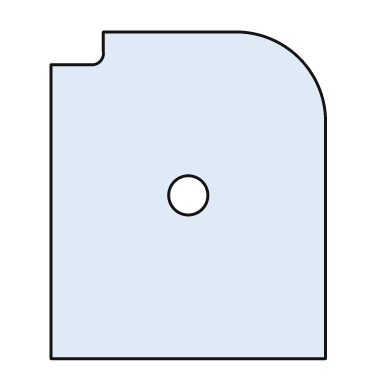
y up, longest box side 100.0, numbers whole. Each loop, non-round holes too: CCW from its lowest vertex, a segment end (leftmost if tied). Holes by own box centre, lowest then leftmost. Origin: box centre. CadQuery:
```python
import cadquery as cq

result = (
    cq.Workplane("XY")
    .moveTo(-42.0, -50.0)
    .lineTo(42.0, -50.0)
    .lineTo(42.0, 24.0)
    .threePointArc((34.0, 42.0), (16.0, 50.0))
    .lineTo(-26.0, 50.0)
    .lineTo(-26.0, 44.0)
    .threePointArc((-27.0, 41.0), (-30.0, 40.0))
    .lineTo(-42.0, 40.0)
    .close()
    .moveTo(0.0, 0.0)
    .circle(6.0)
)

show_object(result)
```